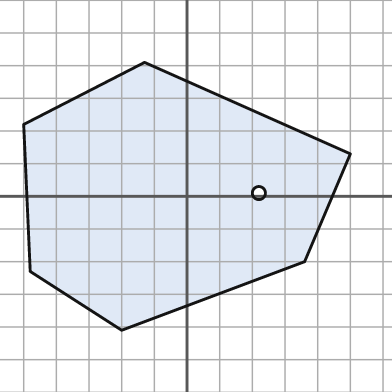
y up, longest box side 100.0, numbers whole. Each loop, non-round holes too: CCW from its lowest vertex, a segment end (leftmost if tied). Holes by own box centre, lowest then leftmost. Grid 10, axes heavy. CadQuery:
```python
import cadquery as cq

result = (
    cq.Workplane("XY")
    .moveTo(-20.0, -41.0)
    .lineTo(36.0, -20.0)
    .lineTo(50.0, 13.0)
    .lineTo(-13.0, 41.0)
    .lineTo(-50.0, 22.0)
    .lineTo(-48.0, -23.0)
    .close()
    .moveTo(22.0, 1.0)
    .circle(2.0)
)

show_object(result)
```